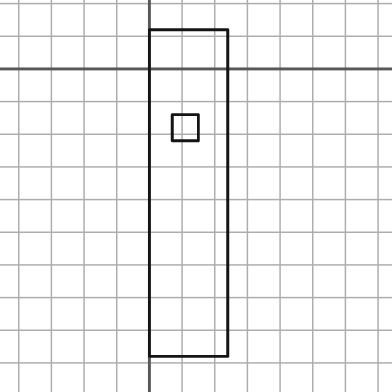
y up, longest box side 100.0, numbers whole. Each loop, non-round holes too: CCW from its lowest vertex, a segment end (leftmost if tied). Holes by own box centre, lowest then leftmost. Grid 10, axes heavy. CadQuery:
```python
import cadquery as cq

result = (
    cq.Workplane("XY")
    .moveTo(0.0, -88.0)
    .lineTo(24.0, -88.0)
    .lineTo(24.0, 12.0)
    .lineTo(0.0, 12.0)
    .close()
    .moveTo(7.0, -22.0)
    .lineTo(15.0, -22.0)
    .lineTo(15.0, -14.0)
    .lineTo(7.0, -14.0)
    .close()
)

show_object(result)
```